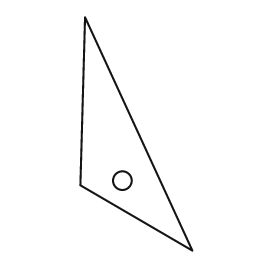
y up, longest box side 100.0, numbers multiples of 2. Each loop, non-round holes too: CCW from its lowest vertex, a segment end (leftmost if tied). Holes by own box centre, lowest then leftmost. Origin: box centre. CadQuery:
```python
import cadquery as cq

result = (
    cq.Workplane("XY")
    .moveTo(24.0, -50.0)
    .lineTo(-22.0, 50.0)
    .lineTo(-24.0, -22.0)
    .close()
    .moveTo(-6.0, -20.0)
    .circle(4.0)
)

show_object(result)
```